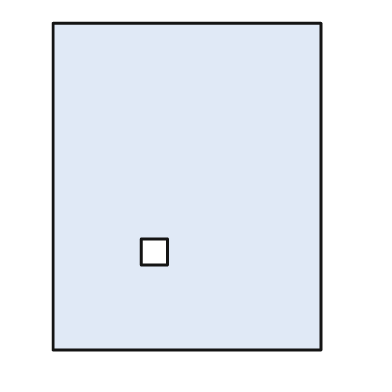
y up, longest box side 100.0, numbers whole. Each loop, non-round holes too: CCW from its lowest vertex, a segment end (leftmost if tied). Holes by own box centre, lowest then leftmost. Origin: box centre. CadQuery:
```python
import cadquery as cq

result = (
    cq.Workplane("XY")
    .moveTo(-41.0, -50.0)
    .lineTo(41.0, -50.0)
    .lineTo(41.0, 50.0)
    .lineTo(-41.0, 50.0)
    .close()
    .moveTo(-14.0, -24.0)
    .lineTo(-6.0, -24.0)
    .lineTo(-6.0, -16.0)
    .lineTo(-14.0, -16.0)
    .close()
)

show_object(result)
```